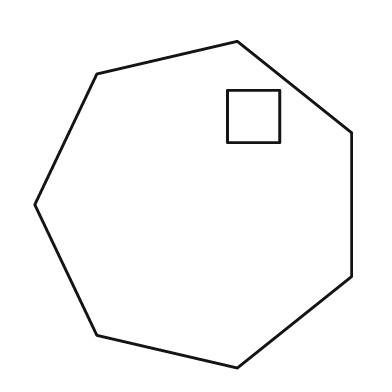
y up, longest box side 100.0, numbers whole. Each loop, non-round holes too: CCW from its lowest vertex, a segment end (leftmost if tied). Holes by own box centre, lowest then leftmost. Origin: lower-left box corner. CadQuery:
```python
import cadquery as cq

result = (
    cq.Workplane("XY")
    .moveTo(62.0, 0.0)
    .lineTo(97.0, 28.0)
    .lineTo(97.0, 72.0)
    .lineTo(62.0, 100.0)
    .lineTo(19.0, 90.0)
    .lineTo(0.0, 50.0)
    .lineTo(19.0, 10.0)
    .close()
    .moveTo(59.0, 69.0)
    .lineTo(75.0, 69.0)
    .lineTo(75.0, 85.0)
    .lineTo(59.0, 85.0)
    .close()
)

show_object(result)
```